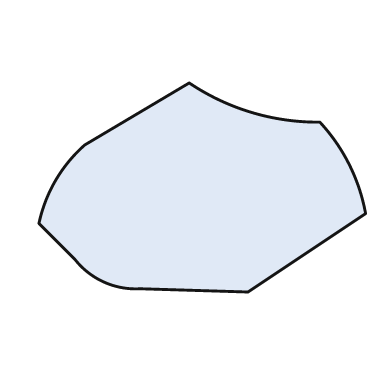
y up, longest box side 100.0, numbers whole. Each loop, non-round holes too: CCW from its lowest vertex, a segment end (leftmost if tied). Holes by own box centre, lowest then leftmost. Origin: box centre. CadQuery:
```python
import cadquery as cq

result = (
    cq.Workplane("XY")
    .moveTo(14.0, -32.0)
    .lineTo(50.0, -8.0)
    .threePointArc((45.0, 7.0), (36.0, 20.0))
    .threePointArc((15.0, 23.0), (-4.0, 32.0))
    .lineTo(-36.0, 13.0)
    .threePointArc((-45.0, 2.0), (-50.0, -11.0))
    .lineTo(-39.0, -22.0)
    .threePointArc((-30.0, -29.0), (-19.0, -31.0))
    .close()
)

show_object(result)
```